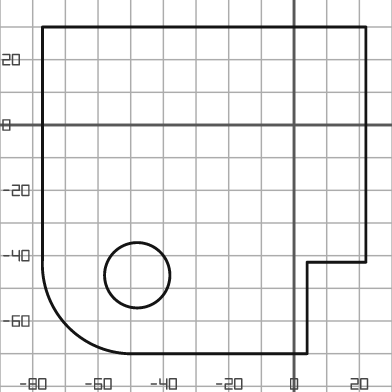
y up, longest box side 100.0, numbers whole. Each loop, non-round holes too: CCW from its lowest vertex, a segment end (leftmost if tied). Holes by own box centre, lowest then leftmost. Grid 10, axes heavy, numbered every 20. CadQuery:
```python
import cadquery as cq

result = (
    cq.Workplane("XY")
    .moveTo(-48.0, -70.0)
    .lineTo(4.0, -70.0)
    .lineTo(4.0, -42.0)
    .lineTo(22.0, -42.0)
    .lineTo(22.0, 30.0)
    .lineTo(-77.0, 30.0)
    .lineTo(-77.0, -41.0)
    .threePointArc((-69.0, -62.0), (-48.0, -70.0))
    .close()
    .moveTo(-48.0, -46.0)
    .circle(10.0)
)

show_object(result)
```